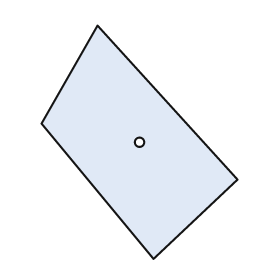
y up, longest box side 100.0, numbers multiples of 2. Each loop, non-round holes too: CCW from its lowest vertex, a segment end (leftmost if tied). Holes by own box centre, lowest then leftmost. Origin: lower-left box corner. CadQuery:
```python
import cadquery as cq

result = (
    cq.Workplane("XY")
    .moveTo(48.0, 0.0)
    .lineTo(84.0, 34.0)
    .lineTo(24.0, 100.0)
    .lineTo(0.0, 58.0)
    .close()
    .moveTo(42.0, 50.0)
    .circle(2.0)
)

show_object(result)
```